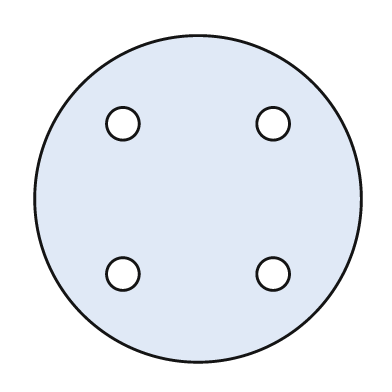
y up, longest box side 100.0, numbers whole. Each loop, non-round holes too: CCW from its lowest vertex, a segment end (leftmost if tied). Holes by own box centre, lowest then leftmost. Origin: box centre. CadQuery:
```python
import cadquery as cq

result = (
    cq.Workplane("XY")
    .moveTo(0.0, 0.0)
    .circle(50.0)
    .moveTo(-23.0, -23.0)
    .circle(5.0)
    .moveTo(23.0, -23.0)
    .circle(5.0)
    .moveTo(-23.0, 23.0)
    .circle(5.0)
    .moveTo(23.0, 23.0)
    .circle(5.0)
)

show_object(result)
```